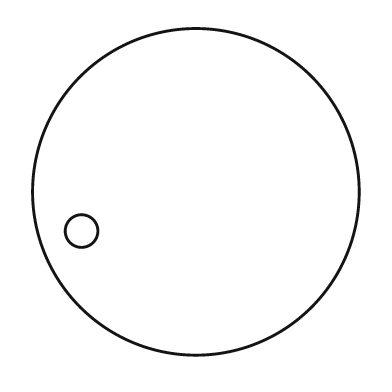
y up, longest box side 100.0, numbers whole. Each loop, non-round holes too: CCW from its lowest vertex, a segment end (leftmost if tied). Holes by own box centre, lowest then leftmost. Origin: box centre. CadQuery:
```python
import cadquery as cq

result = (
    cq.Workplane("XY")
    .moveTo(0.0, 0.0)
    .circle(50.0)
    .moveTo(-35.0, -12.0)
    .circle(5.0)
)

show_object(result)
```